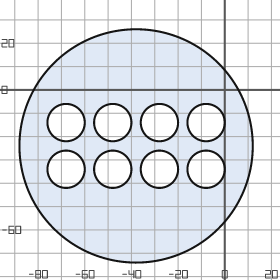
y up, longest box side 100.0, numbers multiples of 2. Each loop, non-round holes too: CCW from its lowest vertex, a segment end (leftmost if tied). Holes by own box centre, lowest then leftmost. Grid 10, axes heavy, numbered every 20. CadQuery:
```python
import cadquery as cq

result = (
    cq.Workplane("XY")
    .moveTo(-38.0, -24.0)
    .circle(50.0)
    .moveTo(-68.0, -34.0)
    .circle(8.0)
    .moveTo(-48.0, -34.0)
    .circle(8.0)
    .moveTo(-28.0, -34.0)
    .circle(8.0)
    .moveTo(-8.0, -34.0)
    .circle(8.0)
    .moveTo(-68.0, -14.0)
    .circle(8.0)
    .moveTo(-48.0, -14.0)
    .circle(8.0)
    .moveTo(-28.0, -14.0)
    .circle(8.0)
    .moveTo(-8.0, -14.0)
    .circle(8.0)
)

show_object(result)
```